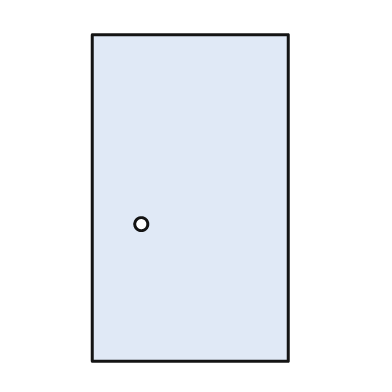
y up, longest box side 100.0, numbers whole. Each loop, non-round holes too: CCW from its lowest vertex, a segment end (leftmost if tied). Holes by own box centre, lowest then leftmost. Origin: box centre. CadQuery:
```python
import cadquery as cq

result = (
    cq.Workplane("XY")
    .moveTo(-30.0, -50.0)
    .lineTo(30.0, -50.0)
    .lineTo(30.0, 50.0)
    .lineTo(-30.0, 50.0)
    .close()
    .moveTo(-15.0, -8.0)
    .circle(2.0)
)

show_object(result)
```